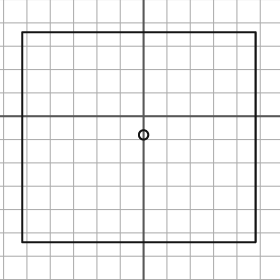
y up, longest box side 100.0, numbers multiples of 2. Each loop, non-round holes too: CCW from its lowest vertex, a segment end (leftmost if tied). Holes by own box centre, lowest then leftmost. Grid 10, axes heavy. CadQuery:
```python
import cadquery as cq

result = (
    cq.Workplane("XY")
    .moveTo(-52.0, -54.0)
    .lineTo(48.0, -54.0)
    .lineTo(48.0, 36.0)
    .lineTo(-52.0, 36.0)
    .close()
    .moveTo(0.0, -8.0)
    .circle(2.0)
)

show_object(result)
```